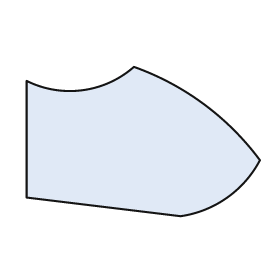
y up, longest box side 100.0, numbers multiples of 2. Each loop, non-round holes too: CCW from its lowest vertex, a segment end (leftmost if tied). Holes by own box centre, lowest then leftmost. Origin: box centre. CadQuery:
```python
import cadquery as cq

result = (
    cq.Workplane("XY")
    .moveTo(16.0, -32.0)
    .threePointArc((36.0, -24.0), (50.0, -8.0))
    .threePointArc((26.0, 16.0), (-4.0, 32.0))
    .threePointArc((-26.0, 22.0), (-50.0, 26.0))
    .lineTo(-50.0, -24.0)
    .close()
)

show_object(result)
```